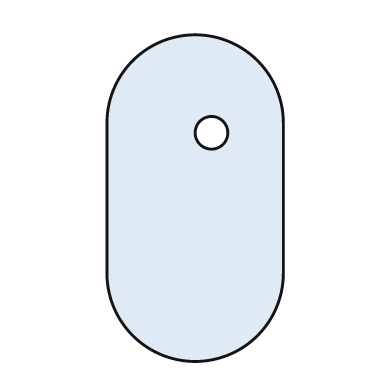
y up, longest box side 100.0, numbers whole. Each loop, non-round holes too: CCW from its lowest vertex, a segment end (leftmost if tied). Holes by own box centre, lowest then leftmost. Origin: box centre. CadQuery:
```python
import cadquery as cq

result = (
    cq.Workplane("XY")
    .moveTo(-27.0, -23.0)
    .threePointArc((0.0, -50.0), (27.0, -23.0))
    .lineTo(27.0, 23.0)
    .threePointArc((0.0, 50.0), (-27.0, 23.0))
    .close()
    .moveTo(5.0, 20.0)
    .circle(5.0)
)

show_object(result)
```